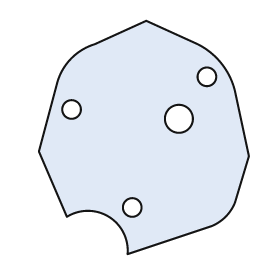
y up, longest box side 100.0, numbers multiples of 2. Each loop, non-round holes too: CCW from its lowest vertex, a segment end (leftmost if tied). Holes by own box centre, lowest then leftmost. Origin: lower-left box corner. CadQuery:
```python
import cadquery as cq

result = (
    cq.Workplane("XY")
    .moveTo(38.0, 0.0)
    .lineTo(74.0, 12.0)
    .threePointArc((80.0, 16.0), (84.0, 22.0))
    .lineTo(90.0, 42.0)
    .lineTo(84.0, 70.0)
    .threePointArc((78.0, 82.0), (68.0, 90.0))
    .lineTo(46.0, 100.0)
    .lineTo(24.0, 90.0)
    .threePointArc((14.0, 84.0), (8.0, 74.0))
    .lineTo(0.0, 44.0)
    .lineTo(12.0, 16.0)
    .threePointArc((30.0, 16.0), (38.0, 0.0))
    .close()
    .moveTo(40.0, 20.0)
    .circle(4.0)
    .moveTo(60.0, 58.0)
    .circle(6.0)
    .moveTo(14.0, 62.0)
    .circle(4.0)
    .moveTo(72.0, 76.0)
    .circle(4.0)
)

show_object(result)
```